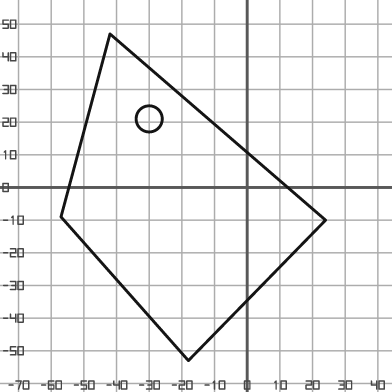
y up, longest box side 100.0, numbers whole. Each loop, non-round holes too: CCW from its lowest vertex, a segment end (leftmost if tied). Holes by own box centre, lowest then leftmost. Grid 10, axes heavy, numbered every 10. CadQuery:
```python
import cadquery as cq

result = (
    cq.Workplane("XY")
    .moveTo(-18.0, -53.0)
    .lineTo(24.0, -10.0)
    .lineTo(-42.0, 47.0)
    .lineTo(-57.0, -9.0)
    .close()
    .moveTo(-30.0, 21.0)
    .circle(4.0)
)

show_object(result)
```